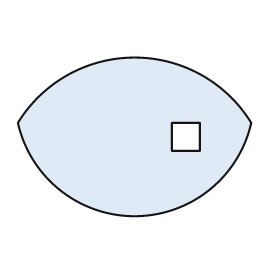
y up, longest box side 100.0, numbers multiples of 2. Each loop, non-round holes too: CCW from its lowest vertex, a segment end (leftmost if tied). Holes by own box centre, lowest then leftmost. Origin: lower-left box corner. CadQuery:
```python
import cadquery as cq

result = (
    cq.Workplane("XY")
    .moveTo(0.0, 40.0)
    .threePointArc((50.0, 0.0), (100.0, 40.0))
    .threePointArc((50.0, 68.0), (0.0, 40.0))
    .close()
    .moveTo(66.0, 28.0)
    .lineTo(78.0, 28.0)
    .lineTo(78.0, 40.0)
    .lineTo(66.0, 40.0)
    .close()
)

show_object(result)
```